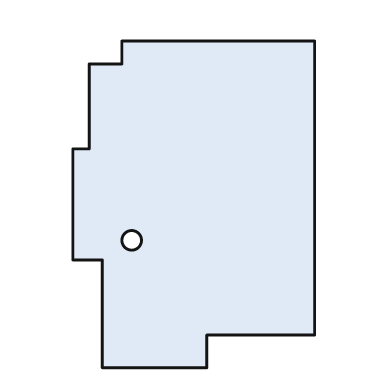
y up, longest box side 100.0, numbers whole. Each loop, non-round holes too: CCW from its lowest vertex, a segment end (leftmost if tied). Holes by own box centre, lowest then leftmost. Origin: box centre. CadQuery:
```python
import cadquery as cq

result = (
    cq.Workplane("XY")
    .moveTo(-28.0, -50.0)
    .lineTo(4.0, -50.0)
    .lineTo(4.0, -40.0)
    .lineTo(37.0, -40.0)
    .lineTo(37.0, 50.0)
    .lineTo(-22.0, 50.0)
    .lineTo(-22.0, 43.0)
    .lineTo(-32.0, 43.0)
    .lineTo(-32.0, 17.0)
    .lineTo(-37.0, 17.0)
    .lineTo(-37.0, -17.0)
    .lineTo(-28.0, -17.0)
    .close()
    .moveTo(-19.0, -11.0)
    .circle(3.0)
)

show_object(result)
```